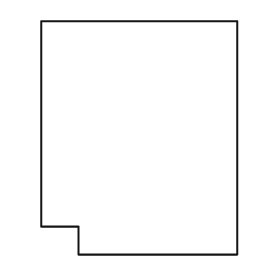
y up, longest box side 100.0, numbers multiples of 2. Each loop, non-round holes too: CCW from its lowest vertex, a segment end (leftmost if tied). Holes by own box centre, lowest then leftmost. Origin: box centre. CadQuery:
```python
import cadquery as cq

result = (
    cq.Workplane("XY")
    .moveTo(-26.0, -50.0)
    .lineTo(42.0, -50.0)
    .lineTo(42.0, 50.0)
    .lineTo(-42.0, 50.0)
    .lineTo(-42.0, -38.0)
    .lineTo(-26.0, -38.0)
    .close()
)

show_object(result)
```